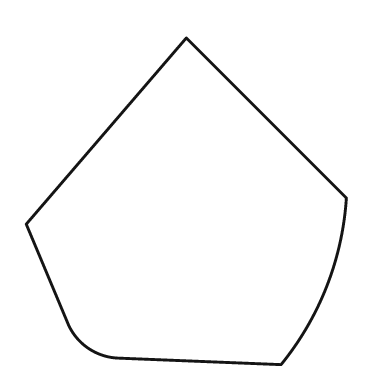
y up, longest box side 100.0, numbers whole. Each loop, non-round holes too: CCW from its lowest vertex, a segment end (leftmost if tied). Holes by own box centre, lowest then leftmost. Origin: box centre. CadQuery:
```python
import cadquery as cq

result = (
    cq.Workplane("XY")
    .moveTo(29.0, -50.0)
    .threePointArc((43.0, -26.0), (49.0, 1.0))
    .lineTo(0.0, 50.0)
    .lineTo(-49.0, -7.0)
    .lineTo(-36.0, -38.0)
    .threePointArc((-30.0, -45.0), (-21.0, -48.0))
    .close()
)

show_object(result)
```